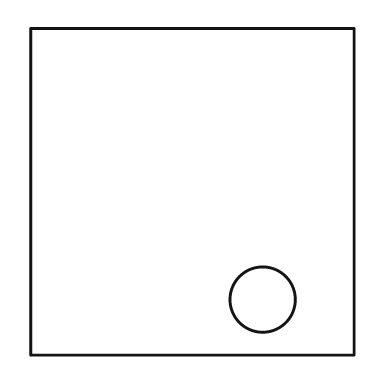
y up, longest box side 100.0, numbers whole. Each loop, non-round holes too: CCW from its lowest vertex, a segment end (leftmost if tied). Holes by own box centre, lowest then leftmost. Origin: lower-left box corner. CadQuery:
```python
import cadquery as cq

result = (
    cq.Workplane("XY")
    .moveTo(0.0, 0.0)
    .lineTo(99.0, 0.0)
    .lineTo(99.0, 100.0)
    .lineTo(0.0, 100.0)
    .close()
    .moveTo(71.0, 17.0)
    .circle(10.0)
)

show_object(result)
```